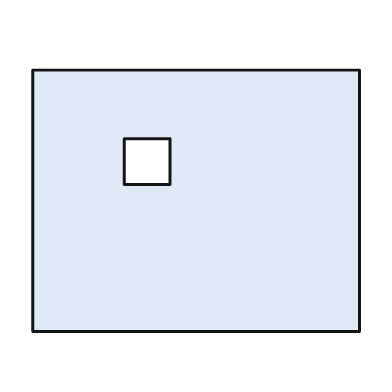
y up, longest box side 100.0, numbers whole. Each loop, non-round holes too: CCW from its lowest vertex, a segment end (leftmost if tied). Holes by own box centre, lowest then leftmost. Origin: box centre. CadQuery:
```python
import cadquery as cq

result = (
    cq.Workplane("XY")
    .moveTo(-50.0, -40.0)
    .lineTo(50.0, -40.0)
    .lineTo(50.0, 40.0)
    .lineTo(-50.0, 40.0)
    .close()
    .moveTo(-22.0, 5.0)
    .lineTo(-8.0, 5.0)
    .lineTo(-8.0, 19.0)
    .lineTo(-22.0, 19.0)
    .close()
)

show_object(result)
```